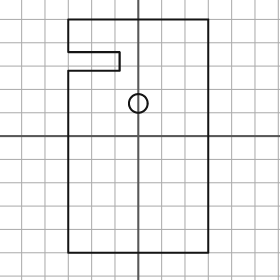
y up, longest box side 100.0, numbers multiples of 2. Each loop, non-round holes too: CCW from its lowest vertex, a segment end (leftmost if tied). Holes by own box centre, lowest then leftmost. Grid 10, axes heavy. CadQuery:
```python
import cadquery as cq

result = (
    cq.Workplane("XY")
    .moveTo(-30.0, -50.0)
    .lineTo(30.0, -50.0)
    .lineTo(30.0, 50.0)
    .lineTo(-30.0, 50.0)
    .lineTo(-30.0, 36.0)
    .lineTo(-8.0, 36.0)
    .lineTo(-8.0, 28.0)
    .lineTo(-30.0, 28.0)
    .close()
    .moveTo(0.0, 14.0)
    .circle(4.0)
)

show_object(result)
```